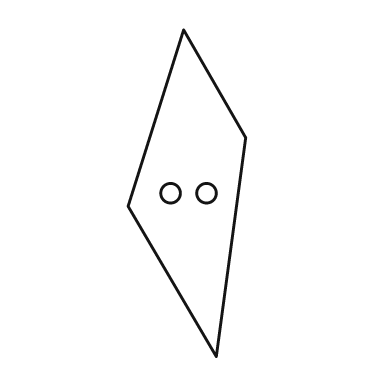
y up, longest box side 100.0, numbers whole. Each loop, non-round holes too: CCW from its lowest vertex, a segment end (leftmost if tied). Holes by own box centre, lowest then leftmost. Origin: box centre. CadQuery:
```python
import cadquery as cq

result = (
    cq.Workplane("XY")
    .moveTo(9.0, -50.0)
    .lineTo(18.0, 17.0)
    .lineTo(-1.0, 50.0)
    .lineTo(-18.0, -4.0)
    .close()
    .moveTo(-5.0, 0.0)
    .circle(3.0)
    .moveTo(6.0, 0.0)
    .circle(3.0)
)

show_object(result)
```